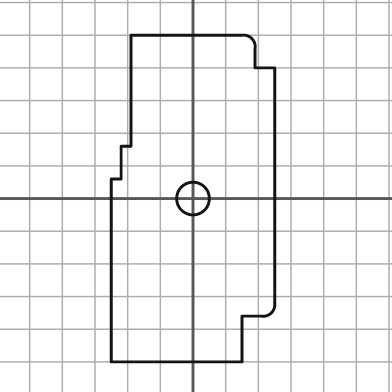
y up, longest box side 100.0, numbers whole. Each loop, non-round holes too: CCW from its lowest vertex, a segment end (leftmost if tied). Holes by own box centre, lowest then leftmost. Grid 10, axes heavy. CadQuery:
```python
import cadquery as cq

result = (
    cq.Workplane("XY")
    .moveTo(-25.0, -50.0)
    .lineTo(15.0, -50.0)
    .lineTo(15.0, -36.0)
    .lineTo(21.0, -36.0)
    .threePointArc((24.0, -35.0), (25.0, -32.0))
    .lineTo(25.0, 40.0)
    .lineTo(19.0, 40.0)
    .lineTo(19.0, 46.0)
    .threePointArc((18.0, 49.0), (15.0, 50.0))
    .lineTo(-19.0, 50.0)
    .lineTo(-19.0, 16.0)
    .lineTo(-22.0, 16.0)
    .lineTo(-22.0, 6.0)
    .lineTo(-25.0, 6.0)
    .close()
    .moveTo(0.0, 0.0)
    .circle(5.0)
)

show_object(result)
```